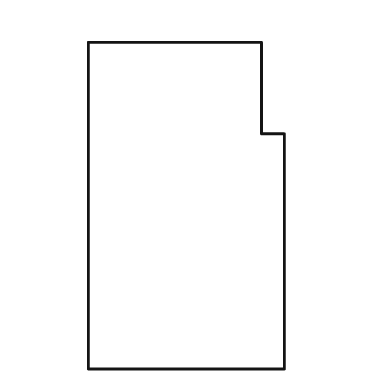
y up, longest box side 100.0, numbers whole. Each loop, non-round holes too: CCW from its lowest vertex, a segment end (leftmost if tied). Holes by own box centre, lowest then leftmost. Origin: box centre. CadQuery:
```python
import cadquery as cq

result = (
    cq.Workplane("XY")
    .moveTo(-30.0, -50.0)
    .lineTo(30.0, -50.0)
    .lineTo(30.0, 22.0)
    .lineTo(23.0, 22.0)
    .lineTo(23.0, 50.0)
    .lineTo(-30.0, 50.0)
    .close()
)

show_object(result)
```